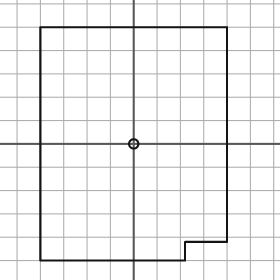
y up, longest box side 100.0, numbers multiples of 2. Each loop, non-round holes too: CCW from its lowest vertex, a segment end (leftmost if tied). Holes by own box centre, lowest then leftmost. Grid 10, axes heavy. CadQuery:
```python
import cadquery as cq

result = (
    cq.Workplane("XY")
    .moveTo(-40.0, -50.0)
    .lineTo(22.0, -50.0)
    .lineTo(22.0, -42.0)
    .lineTo(40.0, -42.0)
    .lineTo(40.0, 50.0)
    .lineTo(-40.0, 50.0)
    .close()
    .moveTo(0.0, 0.0)
    .circle(2.0)
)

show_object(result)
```